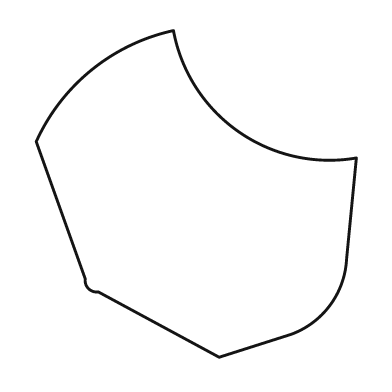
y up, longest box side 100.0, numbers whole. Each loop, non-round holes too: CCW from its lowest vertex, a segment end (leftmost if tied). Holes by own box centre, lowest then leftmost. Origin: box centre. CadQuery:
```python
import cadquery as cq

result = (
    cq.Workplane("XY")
    .moveTo(7.0, -50.0)
    .lineTo(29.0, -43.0)
    .threePointArc((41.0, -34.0), (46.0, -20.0))
    .lineTo(49.0, 11.0)
    .threePointArc((13.0, 19.0), (-7.0, 50.0))
    .threePointArc((-32.0, 38.0), (-49.0, 16.0))
    .lineTo(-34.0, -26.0)
    .threePointArc((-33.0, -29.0), (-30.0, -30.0))
    .close()
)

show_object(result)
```